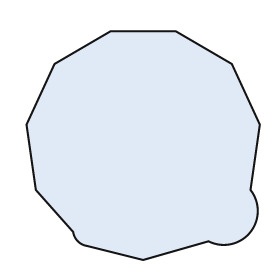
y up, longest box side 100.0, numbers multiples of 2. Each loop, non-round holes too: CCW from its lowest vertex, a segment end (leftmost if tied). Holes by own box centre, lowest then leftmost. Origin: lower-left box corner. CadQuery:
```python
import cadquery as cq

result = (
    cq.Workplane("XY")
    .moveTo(50.0, 0.0)
    .lineTo(78.0, 8.0)
    .threePointArc((96.0, 12.0), (96.0, 30.0))
    .lineTo(100.0, 58.0)
    .lineTo(88.0, 84.0)
    .lineTo(64.0, 98.0)
    .lineTo(36.0, 98.0)
    .lineTo(12.0, 84.0)
    .lineTo(0.0, 58.0)
    .lineTo(4.0, 30.0)
    .lineTo(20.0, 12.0)
    .threePointArc((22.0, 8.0), (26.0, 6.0))
    .close()
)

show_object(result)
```